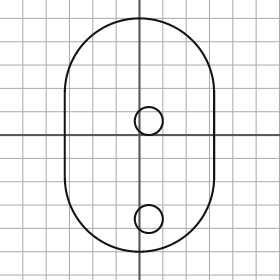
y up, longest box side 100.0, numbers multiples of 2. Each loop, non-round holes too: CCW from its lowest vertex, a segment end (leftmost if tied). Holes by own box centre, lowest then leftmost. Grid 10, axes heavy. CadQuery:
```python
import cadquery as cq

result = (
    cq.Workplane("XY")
    .moveTo(-32.0, -18.0)
    .threePointArc((0.0, -50.0), (32.0, -18.0))
    .lineTo(32.0, 18.0)
    .threePointArc((0.0, 50.0), (-32.0, 18.0))
    .close()
    .moveTo(4.0, -36.0)
    .circle(6.0)
    .moveTo(4.0, 6.0)
    .circle(6.0)
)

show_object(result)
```